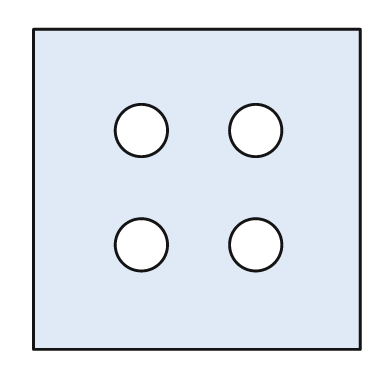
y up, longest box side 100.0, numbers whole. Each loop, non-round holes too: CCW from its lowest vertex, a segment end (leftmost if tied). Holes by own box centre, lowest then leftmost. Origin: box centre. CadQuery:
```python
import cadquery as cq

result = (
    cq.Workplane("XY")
    .moveTo(-50.0, -49.0)
    .lineTo(50.0, -49.0)
    .lineTo(50.0, 49.0)
    .lineTo(-50.0, 49.0)
    .close()
    .moveTo(-17.0, -17.0)
    .circle(8.0)
    .moveTo(18.0, -17.0)
    .circle(8.0)
    .moveTo(-17.0, 18.0)
    .circle(8.0)
    .moveTo(18.0, 18.0)
    .circle(8.0)
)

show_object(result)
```